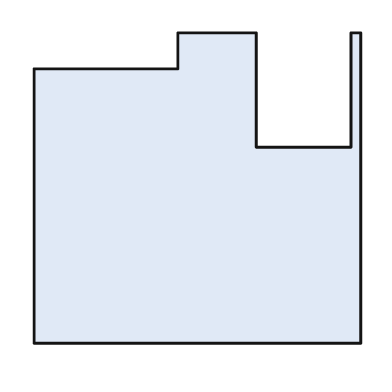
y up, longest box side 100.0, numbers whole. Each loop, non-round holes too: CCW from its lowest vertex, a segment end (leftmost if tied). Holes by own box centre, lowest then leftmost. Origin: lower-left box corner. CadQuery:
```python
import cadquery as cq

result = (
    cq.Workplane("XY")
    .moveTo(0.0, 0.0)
    .lineTo(100.0, 0.0)
    .lineTo(100.0, 95.0)
    .lineTo(97.0, 95.0)
    .lineTo(97.0, 60.0)
    .lineTo(68.0, 60.0)
    .lineTo(68.0, 95.0)
    .lineTo(44.0, 95.0)
    .lineTo(44.0, 84.0)
    .lineTo(0.0, 84.0)
    .close()
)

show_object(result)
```